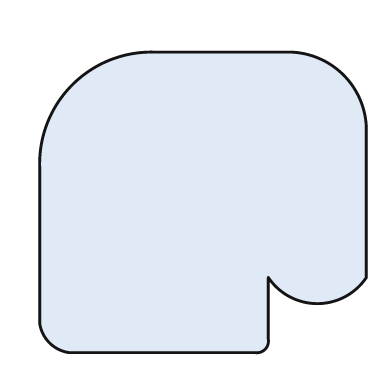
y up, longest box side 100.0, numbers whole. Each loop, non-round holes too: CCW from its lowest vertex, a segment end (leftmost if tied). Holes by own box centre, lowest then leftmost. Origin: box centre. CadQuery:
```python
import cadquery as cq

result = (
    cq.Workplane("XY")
    .moveTo(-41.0, -46.0)
    .lineTo(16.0, -46.0)
    .threePointArc((19.0, -45.0), (20.0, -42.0))
    .lineTo(20.0, -23.0)
    .threePointArc((35.0, -31.0), (50.0, -23.0))
    .lineTo(50.0, 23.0)
    .threePointArc((43.0, 39.0), (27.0, 46.0))
    .lineTo(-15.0, 46.0)
    .threePointArc((-40.0, 36.0), (-50.0, 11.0))
    .lineTo(-50.0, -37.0)
    .threePointArc((-47.0, -43.0), (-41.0, -46.0))
    .close()
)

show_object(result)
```